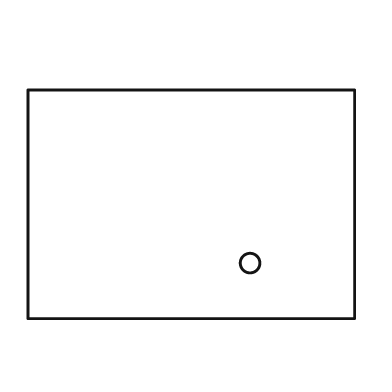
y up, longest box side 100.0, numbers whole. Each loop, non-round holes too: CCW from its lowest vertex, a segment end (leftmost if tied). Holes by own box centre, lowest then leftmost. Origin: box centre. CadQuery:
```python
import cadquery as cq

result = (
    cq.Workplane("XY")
    .moveTo(-50.0, -35.0)
    .lineTo(50.0, -35.0)
    .lineTo(50.0, 35.0)
    .lineTo(-50.0, 35.0)
    .close()
    .moveTo(18.0, -18.0)
    .circle(3.0)
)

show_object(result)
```